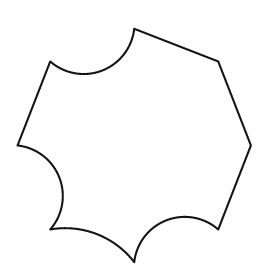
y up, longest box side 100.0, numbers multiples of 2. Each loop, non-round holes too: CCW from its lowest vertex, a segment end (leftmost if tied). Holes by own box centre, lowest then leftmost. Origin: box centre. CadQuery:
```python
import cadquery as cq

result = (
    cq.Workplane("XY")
    .moveTo(0.0, -50.0)
    .threePointArc((14.0, -32.0), (36.0, -36.0))
    .lineTo(50.0, 0.0)
    .lineTo(36.0, 36.0)
    .lineTo(0.0, 50.0)
    .threePointArc((-14.0, 32.0), (-36.0, 36.0))
    .lineTo(-50.0, 0.0)
    .threePointArc((-32.0, -14.0), (-36.0, -36.0))
    .threePointArc((-16.0, -38.0), (0.0, -50.0))
    .close()
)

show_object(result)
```